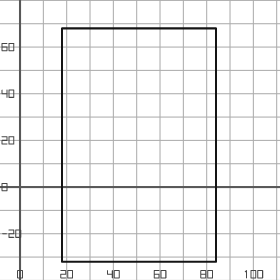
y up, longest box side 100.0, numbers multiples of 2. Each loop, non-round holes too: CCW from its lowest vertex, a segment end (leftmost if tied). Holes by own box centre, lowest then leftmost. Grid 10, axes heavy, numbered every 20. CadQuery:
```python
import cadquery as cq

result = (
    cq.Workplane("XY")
    .moveTo(18.0, -32.0)
    .lineTo(84.0, -32.0)
    .lineTo(84.0, 68.0)
    .lineTo(18.0, 68.0)
    .close()
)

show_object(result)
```